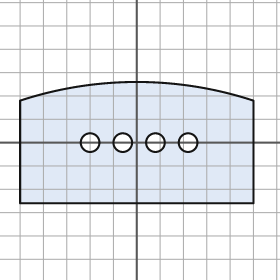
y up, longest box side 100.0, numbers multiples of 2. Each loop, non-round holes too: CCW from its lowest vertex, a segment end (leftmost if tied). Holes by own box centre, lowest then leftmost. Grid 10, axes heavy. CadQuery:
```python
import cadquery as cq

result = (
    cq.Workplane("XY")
    .moveTo(-50.0, -26.0)
    .lineTo(50.0, -26.0)
    .lineTo(50.0, 18.0)
    .threePointArc((0.0, 26.0), (-50.0, 18.0))
    .close()
    .moveTo(-20.0, 0.0)
    .circle(4.0)
    .moveTo(-6.0, 0.0)
    .circle(4.0)
    .moveTo(8.0, 0.0)
    .circle(4.0)
    .moveTo(22.0, 0.0)
    .circle(4.0)
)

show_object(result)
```